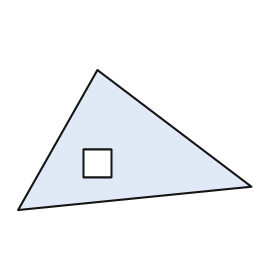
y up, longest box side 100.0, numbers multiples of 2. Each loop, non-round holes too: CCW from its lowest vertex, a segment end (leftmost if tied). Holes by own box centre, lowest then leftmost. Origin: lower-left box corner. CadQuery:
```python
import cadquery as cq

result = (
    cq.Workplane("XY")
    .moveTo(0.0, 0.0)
    .lineTo(100.0, 10.0)
    .lineTo(34.0, 60.0)
    .close()
    .moveTo(28.0, 14.0)
    .lineTo(40.0, 14.0)
    .lineTo(40.0, 26.0)
    .lineTo(28.0, 26.0)
    .close()
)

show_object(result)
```